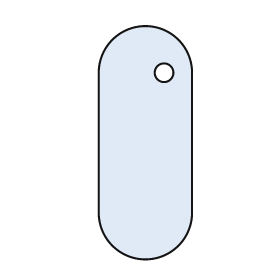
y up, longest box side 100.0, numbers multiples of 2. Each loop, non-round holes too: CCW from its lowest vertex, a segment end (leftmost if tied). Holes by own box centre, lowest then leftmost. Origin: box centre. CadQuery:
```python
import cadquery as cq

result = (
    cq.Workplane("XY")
    .moveTo(-20.0, -30.0)
    .threePointArc((0.0, -50.0), (20.0, -30.0))
    .lineTo(20.0, 30.0)
    .threePointArc((0.0, 50.0), (-20.0, 30.0))
    .close()
    .moveTo(8.0, 30.0)
    .circle(4.0)
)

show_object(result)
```